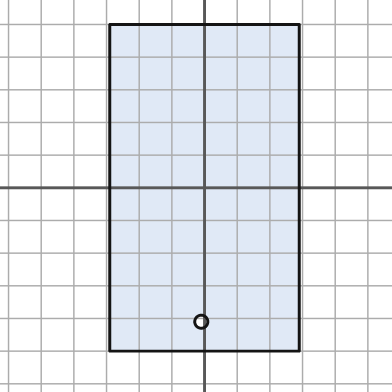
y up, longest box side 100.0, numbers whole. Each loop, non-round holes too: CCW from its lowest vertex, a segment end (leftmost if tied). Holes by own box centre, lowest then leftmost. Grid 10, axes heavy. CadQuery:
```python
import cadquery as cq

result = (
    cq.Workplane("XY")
    .moveTo(-29.0, -50.0)
    .lineTo(29.0, -50.0)
    .lineTo(29.0, 50.0)
    .lineTo(-29.0, 50.0)
    .close()
    .moveTo(-1.0, -41.0)
    .circle(2.0)
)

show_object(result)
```